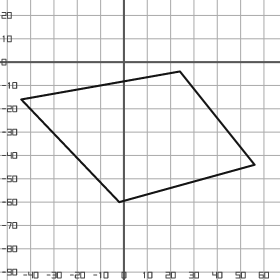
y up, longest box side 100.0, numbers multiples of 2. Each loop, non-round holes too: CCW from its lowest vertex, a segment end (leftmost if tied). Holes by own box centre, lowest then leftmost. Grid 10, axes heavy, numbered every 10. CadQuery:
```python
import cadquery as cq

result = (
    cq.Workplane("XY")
    .moveTo(-2.0, -60.0)
    .lineTo(56.0, -44.0)
    .lineTo(24.0, -4.0)
    .lineTo(-44.0, -16.0)
    .close()
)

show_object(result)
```